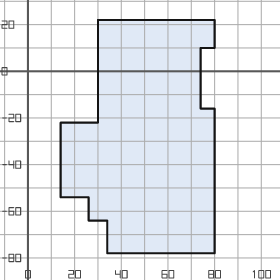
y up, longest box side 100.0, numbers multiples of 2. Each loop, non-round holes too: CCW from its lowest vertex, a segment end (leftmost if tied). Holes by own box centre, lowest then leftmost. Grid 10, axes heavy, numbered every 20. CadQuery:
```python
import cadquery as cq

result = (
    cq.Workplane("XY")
    .moveTo(34.0, -78.0)
    .lineTo(80.0, -78.0)
    .lineTo(80.0, -16.0)
    .lineTo(74.0, -16.0)
    .lineTo(74.0, 10.0)
    .lineTo(80.0, 10.0)
    .lineTo(80.0, 22.0)
    .lineTo(30.0, 22.0)
    .lineTo(30.0, -22.0)
    .lineTo(14.0, -22.0)
    .lineTo(14.0, -54.0)
    .lineTo(26.0, -54.0)
    .lineTo(26.0, -64.0)
    .lineTo(34.0, -64.0)
    .close()
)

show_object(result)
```